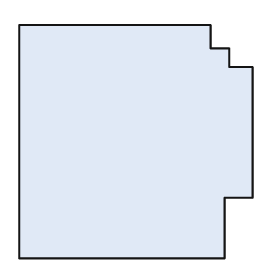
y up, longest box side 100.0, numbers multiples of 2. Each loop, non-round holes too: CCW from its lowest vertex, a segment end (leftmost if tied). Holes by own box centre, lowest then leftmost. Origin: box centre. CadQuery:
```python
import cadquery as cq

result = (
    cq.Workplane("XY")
    .moveTo(-50.0, -50.0)
    .lineTo(38.0, -50.0)
    .lineTo(38.0, -24.0)
    .lineTo(50.0, -24.0)
    .lineTo(50.0, 32.0)
    .lineTo(40.0, 32.0)
    .lineTo(40.0, 40.0)
    .lineTo(32.0, 40.0)
    .lineTo(32.0, 50.0)
    .lineTo(-50.0, 50.0)
    .close()
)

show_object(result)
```